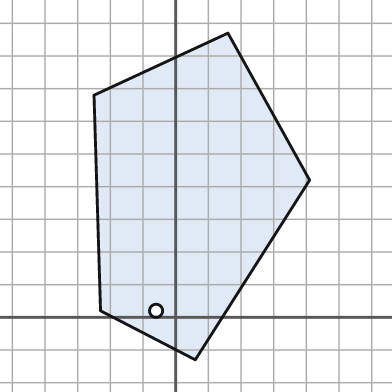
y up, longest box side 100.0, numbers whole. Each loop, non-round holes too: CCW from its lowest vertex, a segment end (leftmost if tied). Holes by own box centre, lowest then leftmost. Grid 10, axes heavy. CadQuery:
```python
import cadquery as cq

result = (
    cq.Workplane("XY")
    .moveTo(6.0, -13.0)
    .lineTo(41.0, 42.0)
    .lineTo(16.0, 87.0)
    .lineTo(-25.0, 68.0)
    .lineTo(-23.0, 2.0)
    .close()
    .moveTo(-6.0, 2.0)
    .circle(2.0)
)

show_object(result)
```